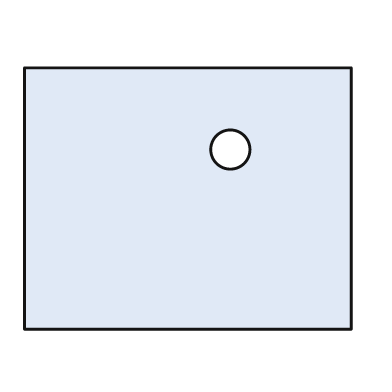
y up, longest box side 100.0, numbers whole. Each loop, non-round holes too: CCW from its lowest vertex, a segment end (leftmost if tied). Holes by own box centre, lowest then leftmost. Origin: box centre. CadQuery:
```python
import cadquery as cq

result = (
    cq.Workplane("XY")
    .moveTo(-50.0, -40.0)
    .lineTo(50.0, -40.0)
    .lineTo(50.0, 40.0)
    .lineTo(-50.0, 40.0)
    .close()
    .moveTo(13.0, 15.0)
    .circle(6.0)
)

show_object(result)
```